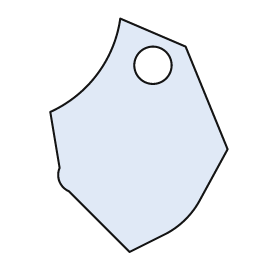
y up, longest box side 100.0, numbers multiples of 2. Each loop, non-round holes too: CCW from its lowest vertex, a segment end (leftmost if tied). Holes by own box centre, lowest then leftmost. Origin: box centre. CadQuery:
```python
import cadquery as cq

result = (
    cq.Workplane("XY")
    .moveTo(-4.0, -50.0)
    .lineTo(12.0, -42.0)
    .threePointArc((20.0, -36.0), (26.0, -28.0))
    .lineTo(38.0, -6.0)
    .lineTo(20.0, 38.0)
    .lineTo(-8.0, 50.0)
    .threePointArc((-18.0, 26.0), (-38.0, 10.0))
    .lineTo(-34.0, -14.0)
    .threePointArc((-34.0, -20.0), (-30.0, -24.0))
    .close()
    .moveTo(6.0, 30.0)
    .circle(8.0)
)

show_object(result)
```